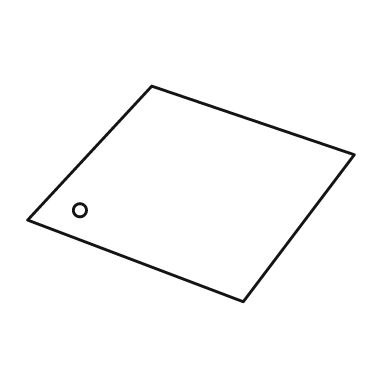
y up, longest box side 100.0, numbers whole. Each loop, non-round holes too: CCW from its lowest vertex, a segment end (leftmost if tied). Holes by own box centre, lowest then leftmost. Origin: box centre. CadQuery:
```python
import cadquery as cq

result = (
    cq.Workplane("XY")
    .moveTo(16.0, -33.0)
    .lineTo(50.0, 12.0)
    .lineTo(-12.0, 33.0)
    .lineTo(-50.0, -8.0)
    .close()
    .moveTo(-34.0, -5.0)
    .circle(2.0)
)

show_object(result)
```